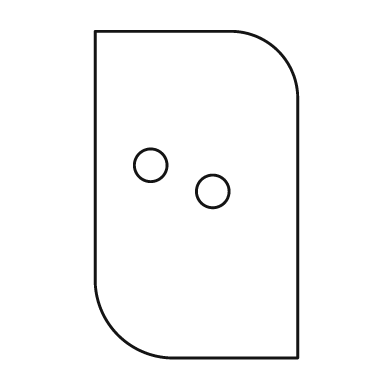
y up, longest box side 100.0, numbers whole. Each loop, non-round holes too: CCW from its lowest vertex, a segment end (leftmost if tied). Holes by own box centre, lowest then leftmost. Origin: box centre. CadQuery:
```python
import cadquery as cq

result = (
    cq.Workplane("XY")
    .moveTo(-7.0, -50.0)
    .lineTo(31.0, -50.0)
    .lineTo(31.0, 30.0)
    .threePointArc((25.0, 44.0), (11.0, 50.0))
    .lineTo(-31.0, 50.0)
    .lineTo(-31.0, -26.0)
    .threePointArc((-24.0, -43.0), (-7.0, -50.0))
    .close()
    .moveTo(5.0, 1.0)
    .circle(5.0)
    .moveTo(-14.0, 9.0)
    .circle(5.0)
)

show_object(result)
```